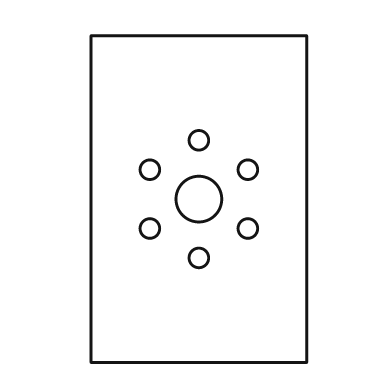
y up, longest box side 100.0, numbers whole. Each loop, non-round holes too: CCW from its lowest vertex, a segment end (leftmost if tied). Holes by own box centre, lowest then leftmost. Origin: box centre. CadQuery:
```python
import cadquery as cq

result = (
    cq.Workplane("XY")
    .moveTo(-33.0, -50.0)
    .lineTo(33.0, -50.0)
    .lineTo(33.0, 50.0)
    .lineTo(-33.0, 50.0)
    .close()
    .moveTo(0.0, -18.0)
    .circle(3.0)
    .moveTo(-15.0, -9.0)
    .circle(3.0)
    .moveTo(15.0, -9.0)
    .circle(3.0)
    .moveTo(0.0, 0.0)
    .circle(7.0)
    .moveTo(-15.0, 9.0)
    .circle(3.0)
    .moveTo(15.0, 9.0)
    .circle(3.0)
    .moveTo(0.0, 18.0)
    .circle(3.0)
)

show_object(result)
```